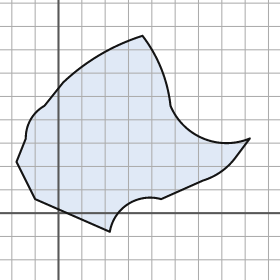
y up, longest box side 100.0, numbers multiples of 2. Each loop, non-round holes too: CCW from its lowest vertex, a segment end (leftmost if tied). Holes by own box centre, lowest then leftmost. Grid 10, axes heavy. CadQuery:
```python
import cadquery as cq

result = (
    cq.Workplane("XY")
    .moveTo(22.0, -8.0)
    .threePointArc((30.0, 4.0), (44.0, 6.0))
    .lineTo(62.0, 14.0)
    .threePointArc((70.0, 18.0), (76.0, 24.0))
    .lineTo(82.0, 32.0)
    .threePointArc((62.0, 32.0), (48.0, 46.0))
    .threePointArc((44.0, 62.0), (36.0, 76.0))
    .threePointArc((18.0, 68.0), (2.0, 56.0))
    .lineTo(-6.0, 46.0)
    .threePointArc((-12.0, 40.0), (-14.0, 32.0))
    .lineTo(-18.0, 22.0)
    .lineTo(-10.0, 6.0)
    .close()
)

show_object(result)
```